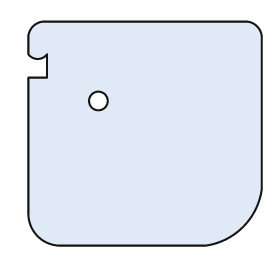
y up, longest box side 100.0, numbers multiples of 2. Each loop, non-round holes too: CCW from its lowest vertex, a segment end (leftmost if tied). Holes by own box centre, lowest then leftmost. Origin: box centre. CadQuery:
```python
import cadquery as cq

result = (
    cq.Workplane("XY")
    .moveTo(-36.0, -48.0)
    .lineTo(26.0, -48.0)
    .threePointArc((42.0, -40.0), (50.0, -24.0))
    .lineTo(50.0, 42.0)
    .threePointArc((48.0, 46.0), (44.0, 48.0))
    .lineTo(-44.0, 48.0)
    .threePointArc((-48.0, 46.0), (-50.0, 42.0))
    .lineTo(-50.0, 34.0)
    .threePointArc((-46.0, 32.0), (-42.0, 34.0))
    .lineTo(-42.0, 24.0)
    .lineTo(-50.0, 24.0)
    .lineTo(-50.0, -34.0)
    .threePointArc((-46.0, -44.0), (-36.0, -48.0))
    .close()
    .moveTo(-20.0, 14.0)
    .circle(4.0)
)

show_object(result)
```